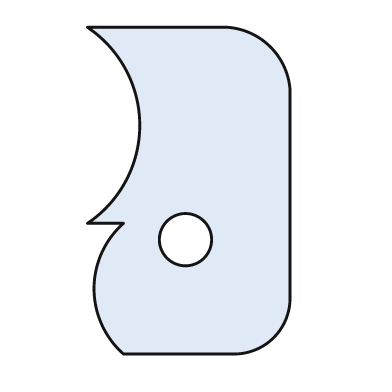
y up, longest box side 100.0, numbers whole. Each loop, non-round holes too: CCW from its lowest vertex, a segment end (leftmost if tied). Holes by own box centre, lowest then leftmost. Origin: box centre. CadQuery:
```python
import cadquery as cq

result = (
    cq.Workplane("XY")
    .moveTo(-20.0, -50.0)
    .lineTo(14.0, -50.0)
    .threePointArc((26.0, -45.0), (31.0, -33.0))
    .lineTo(31.0, 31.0)
    .threePointArc((25.0, 44.0), (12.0, 50.0))
    .lineTo(-31.0, 50.0)
    .threePointArc((-15.0, 20.0), (-31.0, -10.0))
    .lineTo(-20.0, -10.0)
    .threePointArc((-29.0, -30.0), (-20.0, -50.0))
    .close()
    .moveTo(-1.0, -15.0)
    .circle(8.0)
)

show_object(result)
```